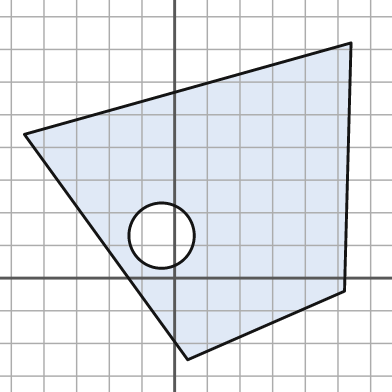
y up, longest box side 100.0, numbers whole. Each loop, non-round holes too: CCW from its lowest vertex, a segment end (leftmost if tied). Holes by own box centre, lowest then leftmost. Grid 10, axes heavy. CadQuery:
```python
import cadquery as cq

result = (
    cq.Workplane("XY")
    .moveTo(4.0, -25.0)
    .lineTo(52.0, -4.0)
    .lineTo(54.0, 72.0)
    .lineTo(-46.0, 44.0)
    .close()
    .moveTo(-4.0, 13.0)
    .circle(10.0)
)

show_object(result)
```